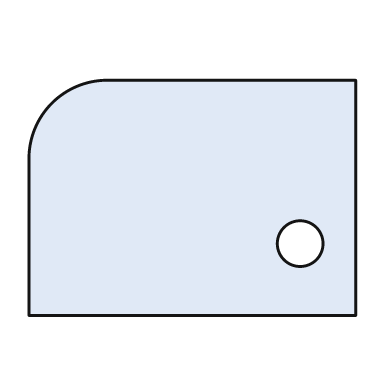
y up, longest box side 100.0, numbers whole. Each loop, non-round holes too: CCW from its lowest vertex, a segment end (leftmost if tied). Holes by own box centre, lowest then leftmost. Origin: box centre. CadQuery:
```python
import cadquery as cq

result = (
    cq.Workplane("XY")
    .moveTo(-50.0, -36.0)
    .lineTo(50.0, -36.0)
    .lineTo(50.0, 36.0)
    .lineTo(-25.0, 36.0)
    .threePointArc((-43.0, 29.0), (-50.0, 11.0))
    .close()
    .moveTo(33.0, -14.0)
    .circle(7.0)
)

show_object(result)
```